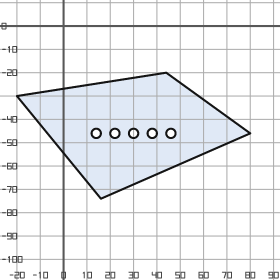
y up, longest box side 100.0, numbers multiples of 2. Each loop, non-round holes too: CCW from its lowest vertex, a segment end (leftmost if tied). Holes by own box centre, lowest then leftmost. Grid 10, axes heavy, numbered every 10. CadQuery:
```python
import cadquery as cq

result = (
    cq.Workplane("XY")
    .moveTo(16.0, -74.0)
    .lineTo(80.0, -46.0)
    .lineTo(44.0, -20.0)
    .lineTo(-20.0, -30.0)
    .close()
    .moveTo(14.0, -46.0)
    .circle(2.0)
    .moveTo(22.0, -46.0)
    .circle(2.0)
    .moveTo(30.0, -46.0)
    .circle(2.0)
    .moveTo(38.0, -46.0)
    .circle(2.0)
    .moveTo(46.0, -46.0)
    .circle(2.0)
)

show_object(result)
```